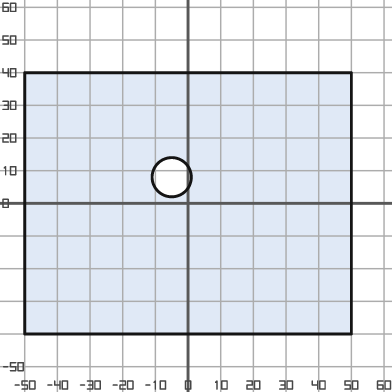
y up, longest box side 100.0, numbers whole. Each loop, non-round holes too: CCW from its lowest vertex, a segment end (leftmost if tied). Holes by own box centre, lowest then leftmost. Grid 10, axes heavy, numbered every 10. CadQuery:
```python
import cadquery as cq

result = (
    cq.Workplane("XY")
    .moveTo(-50.0, -40.0)
    .lineTo(50.0, -40.0)
    .lineTo(50.0, 40.0)
    .lineTo(-50.0, 40.0)
    .close()
    .moveTo(-5.0, 8.0)
    .circle(6.0)
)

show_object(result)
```